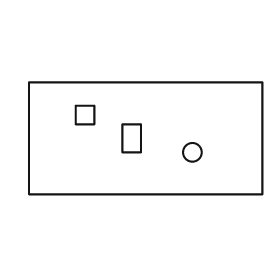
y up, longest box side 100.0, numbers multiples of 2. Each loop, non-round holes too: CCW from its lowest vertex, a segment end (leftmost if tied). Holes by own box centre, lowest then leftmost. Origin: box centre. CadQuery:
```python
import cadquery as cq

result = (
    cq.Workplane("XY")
    .moveTo(-50.0, -24.0)
    .lineTo(50.0, -24.0)
    .lineTo(50.0, 24.0)
    .lineTo(-50.0, 24.0)
    .close()
    .moveTo(20.0, -6.0)
    .circle(4.0)
    .moveTo(-10.0, -6.0)
    .lineTo(-2.0, -6.0)
    .lineTo(-2.0, 6.0)
    .lineTo(-10.0, 6.0)
    .close()
    .moveTo(-30.0, 6.0)
    .lineTo(-22.0, 6.0)
    .lineTo(-22.0, 14.0)
    .lineTo(-30.0, 14.0)
    .close()
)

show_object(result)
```